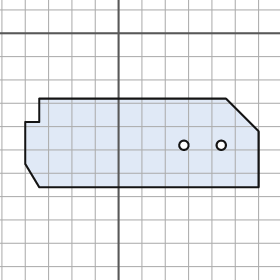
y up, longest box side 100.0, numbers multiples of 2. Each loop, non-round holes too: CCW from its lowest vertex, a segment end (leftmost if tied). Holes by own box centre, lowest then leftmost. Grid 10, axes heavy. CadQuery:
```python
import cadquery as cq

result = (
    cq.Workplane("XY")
    .moveTo(-34.0, -66.0)
    .lineTo(60.0, -66.0)
    .lineTo(60.0, -42.0)
    .lineTo(46.0, -28.0)
    .lineTo(-34.0, -28.0)
    .lineTo(-34.0, -38.0)
    .lineTo(-40.0, -38.0)
    .lineTo(-40.0, -56.0)
    .close()
    .moveTo(28.0, -48.0)
    .circle(2.0)
    .moveTo(44.0, -48.0)
    .circle(2.0)
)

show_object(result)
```